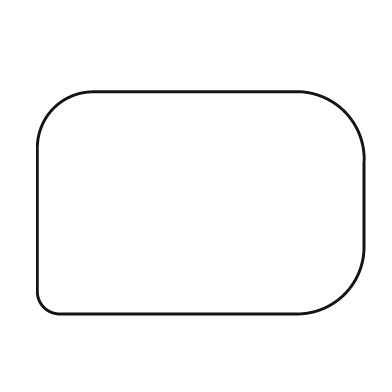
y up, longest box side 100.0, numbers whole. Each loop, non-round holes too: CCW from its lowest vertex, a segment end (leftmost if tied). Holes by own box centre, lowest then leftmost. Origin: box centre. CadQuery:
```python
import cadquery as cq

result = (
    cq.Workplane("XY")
    .moveTo(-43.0, -34.0)
    .lineTo(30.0, -34.0)
    .threePointArc((44.0, -28.0), (50.0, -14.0))
    .lineTo(50.0, 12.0)
    .threePointArc((44.0, 28.0), (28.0, 34.0))
    .lineTo(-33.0, 34.0)
    .threePointArc((-45.0, 29.0), (-50.0, 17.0))
    .lineTo(-50.0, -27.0)
    .threePointArc((-48.0, -32.0), (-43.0, -34.0))
    .close()
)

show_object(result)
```